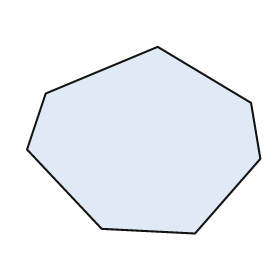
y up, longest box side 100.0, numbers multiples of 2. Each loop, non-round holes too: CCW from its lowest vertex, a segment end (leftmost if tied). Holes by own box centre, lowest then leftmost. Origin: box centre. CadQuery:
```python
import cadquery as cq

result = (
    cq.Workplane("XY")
    .moveTo(22.0, -40.0)
    .lineTo(50.0, -8.0)
    .lineTo(46.0, 16.0)
    .lineTo(6.0, 40.0)
    .lineTo(-42.0, 20.0)
    .lineTo(-50.0, -4.0)
    .lineTo(-18.0, -38.0)
    .close()
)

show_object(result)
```